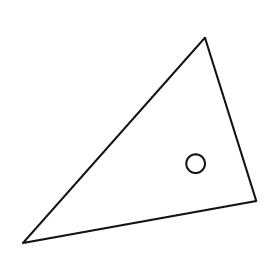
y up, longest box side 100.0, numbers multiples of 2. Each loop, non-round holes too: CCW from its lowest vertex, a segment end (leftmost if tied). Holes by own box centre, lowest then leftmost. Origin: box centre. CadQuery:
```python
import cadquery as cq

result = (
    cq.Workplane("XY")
    .moveTo(-50.0, -44.0)
    .lineTo(50.0, -26.0)
    .lineTo(28.0, 44.0)
    .close()
    .moveTo(24.0, -10.0)
    .circle(4.0)
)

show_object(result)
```